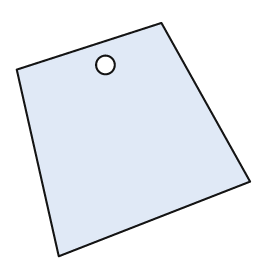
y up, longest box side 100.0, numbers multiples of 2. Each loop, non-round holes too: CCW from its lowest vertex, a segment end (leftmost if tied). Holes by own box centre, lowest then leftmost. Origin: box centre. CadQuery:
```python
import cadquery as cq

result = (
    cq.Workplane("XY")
    .moveTo(-32.0, -50.0)
    .lineTo(50.0, -18.0)
    .lineTo(12.0, 50.0)
    .lineTo(-50.0, 30.0)
    .close()
    .moveTo(-12.0, 32.0)
    .circle(4.0)
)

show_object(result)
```